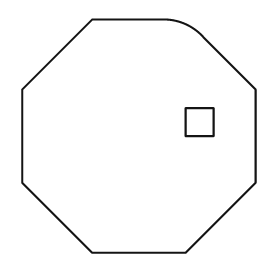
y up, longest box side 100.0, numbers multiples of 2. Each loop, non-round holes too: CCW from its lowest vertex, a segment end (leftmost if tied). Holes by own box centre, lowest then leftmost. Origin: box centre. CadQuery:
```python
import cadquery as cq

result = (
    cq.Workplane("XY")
    .moveTo(-20.0, -50.0)
    .lineTo(20.0, -50.0)
    .lineTo(50.0, -20.0)
    .lineTo(50.0, 20.0)
    .lineTo(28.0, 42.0)
    .threePointArc((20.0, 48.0), (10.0, 50.0))
    .lineTo(-20.0, 50.0)
    .lineTo(-50.0, 20.0)
    .lineTo(-50.0, -20.0)
    .close()
    .moveTo(20.0, 0.0)
    .lineTo(32.0, 0.0)
    .lineTo(32.0, 12.0)
    .lineTo(20.0, 12.0)
    .close()
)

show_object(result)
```